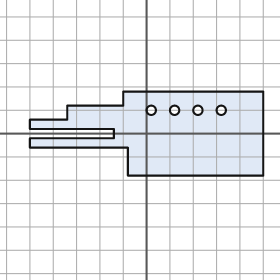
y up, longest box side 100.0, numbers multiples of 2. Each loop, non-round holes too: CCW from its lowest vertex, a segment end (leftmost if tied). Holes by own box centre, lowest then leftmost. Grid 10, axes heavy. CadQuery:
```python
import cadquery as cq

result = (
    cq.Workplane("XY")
    .moveTo(-8.0, -18.0)
    .lineTo(50.0, -18.0)
    .lineTo(50.0, 18.0)
    .lineTo(-10.0, 18.0)
    .lineTo(-10.0, 12.0)
    .lineTo(-34.0, 12.0)
    .lineTo(-34.0, 6.0)
    .lineTo(-50.0, 6.0)
    .lineTo(-50.0, 2.0)
    .lineTo(-14.0, 2.0)
    .lineTo(-14.0, -2.0)
    .lineTo(-50.0, -2.0)
    .lineTo(-50.0, -6.0)
    .lineTo(-8.0, -6.0)
    .close()
    .moveTo(2.0, 10.0)
    .circle(2.0)
    .moveTo(12.0, 10.0)
    .circle(2.0)
    .moveTo(22.0, 10.0)
    .circle(2.0)
    .moveTo(32.0, 10.0)
    .circle(2.0)
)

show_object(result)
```